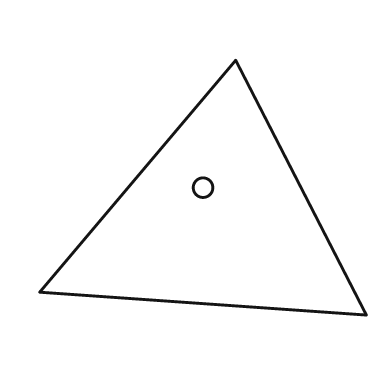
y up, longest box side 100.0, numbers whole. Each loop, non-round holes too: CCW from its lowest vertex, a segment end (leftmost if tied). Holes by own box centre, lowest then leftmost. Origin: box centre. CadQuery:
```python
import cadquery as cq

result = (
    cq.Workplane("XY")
    .moveTo(50.0, -39.0)
    .lineTo(10.0, 39.0)
    .lineTo(-50.0, -32.0)
    .close()
    .moveTo(0.0, 0.0)
    .circle(3.0)
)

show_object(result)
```